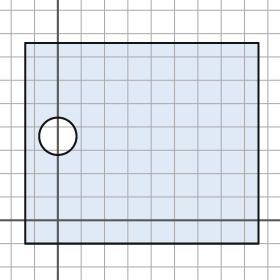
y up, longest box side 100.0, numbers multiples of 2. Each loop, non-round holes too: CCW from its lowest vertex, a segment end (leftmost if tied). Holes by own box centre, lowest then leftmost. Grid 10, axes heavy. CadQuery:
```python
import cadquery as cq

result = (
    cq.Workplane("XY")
    .moveTo(-14.0, -10.0)
    .lineTo(86.0, -10.0)
    .lineTo(86.0, 76.0)
    .lineTo(-14.0, 76.0)
    .close()
    .moveTo(0.0, 36.0)
    .circle(8.0)
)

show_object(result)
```